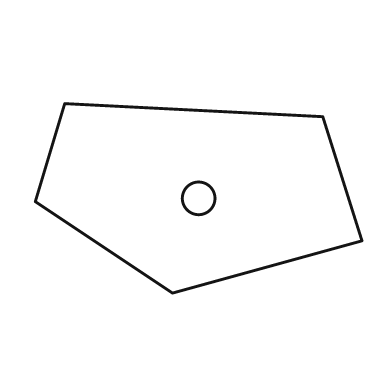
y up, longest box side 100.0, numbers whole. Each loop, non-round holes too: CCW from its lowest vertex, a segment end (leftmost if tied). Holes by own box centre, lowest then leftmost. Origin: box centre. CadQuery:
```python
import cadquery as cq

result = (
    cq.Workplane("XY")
    .moveTo(-8.0, -29.0)
    .lineTo(50.0, -13.0)
    .lineTo(38.0, 25.0)
    .lineTo(-41.0, 29.0)
    .lineTo(-50.0, -1.0)
    .close()
    .moveTo(0.0, 0.0)
    .circle(5.0)
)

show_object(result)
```